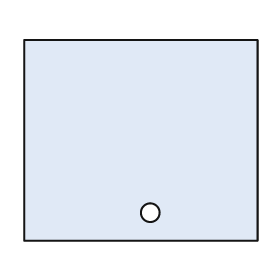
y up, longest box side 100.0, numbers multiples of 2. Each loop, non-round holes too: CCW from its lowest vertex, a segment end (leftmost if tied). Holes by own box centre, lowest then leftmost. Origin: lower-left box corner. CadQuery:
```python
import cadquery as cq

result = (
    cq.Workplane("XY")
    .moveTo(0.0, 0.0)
    .lineTo(100.0, 0.0)
    .lineTo(100.0, 86.0)
    .lineTo(0.0, 86.0)
    .close()
    .moveTo(54.0, 12.0)
    .circle(4.0)
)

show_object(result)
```